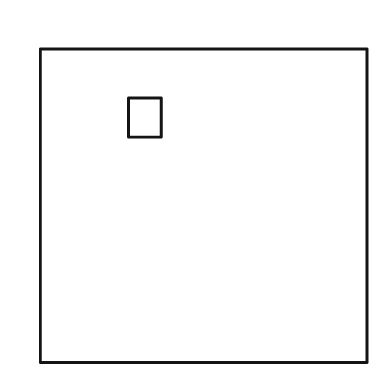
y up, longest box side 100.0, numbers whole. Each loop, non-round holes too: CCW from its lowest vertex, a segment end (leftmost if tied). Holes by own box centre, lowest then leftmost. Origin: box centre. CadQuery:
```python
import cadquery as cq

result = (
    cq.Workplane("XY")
    .moveTo(-50.0, -48.0)
    .lineTo(50.0, -48.0)
    .lineTo(50.0, 48.0)
    .lineTo(-50.0, 48.0)
    .close()
    .moveTo(-23.0, 21.0)
    .lineTo(-13.0, 21.0)
    .lineTo(-13.0, 33.0)
    .lineTo(-23.0, 33.0)
    .close()
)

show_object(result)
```